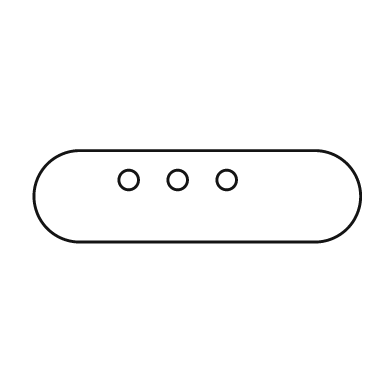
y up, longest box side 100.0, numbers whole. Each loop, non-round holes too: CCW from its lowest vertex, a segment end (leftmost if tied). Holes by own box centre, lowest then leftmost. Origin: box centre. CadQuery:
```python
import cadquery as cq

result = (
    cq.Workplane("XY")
    .moveTo(-36.0, -14.0)
    .lineTo(36.0, -14.0)
    .threePointArc((50.0, 0.0), (36.0, 14.0))
    .lineTo(-36.0, 14.0)
    .threePointArc((-50.0, 0.0), (-36.0, -14.0))
    .close()
    .moveTo(-21.0, 5.0)
    .circle(3.0)
    .moveTo(-6.0, 5.0)
    .circle(3.0)
    .moveTo(9.0, 5.0)
    .circle(3.0)
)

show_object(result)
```